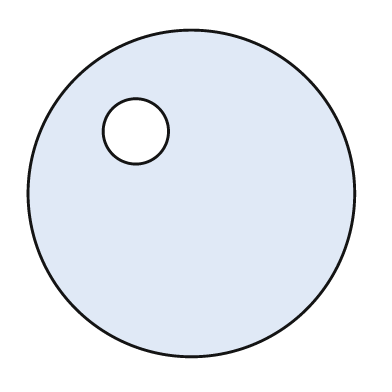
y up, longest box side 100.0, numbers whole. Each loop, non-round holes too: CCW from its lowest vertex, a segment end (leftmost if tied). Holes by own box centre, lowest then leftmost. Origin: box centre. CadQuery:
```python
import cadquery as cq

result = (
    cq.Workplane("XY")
    .moveTo(0.0, 0.0)
    .circle(50.0)
    .moveTo(-17.0, 19.0)
    .circle(10.0)
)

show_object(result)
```